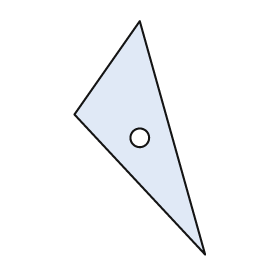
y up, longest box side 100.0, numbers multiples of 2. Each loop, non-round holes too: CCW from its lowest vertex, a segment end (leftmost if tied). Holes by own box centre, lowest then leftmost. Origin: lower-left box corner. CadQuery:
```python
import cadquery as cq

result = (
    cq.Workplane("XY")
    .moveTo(56.0, 0.0)
    .lineTo(28.0, 100.0)
    .lineTo(0.0, 60.0)
    .close()
    .moveTo(28.0, 50.0)
    .circle(4.0)
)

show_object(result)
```